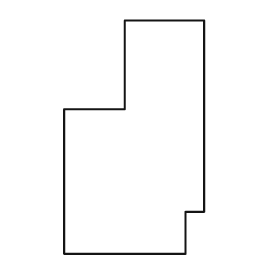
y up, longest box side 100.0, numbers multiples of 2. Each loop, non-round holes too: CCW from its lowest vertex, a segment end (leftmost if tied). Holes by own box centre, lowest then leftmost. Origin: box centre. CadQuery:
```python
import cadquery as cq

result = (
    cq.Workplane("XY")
    .moveTo(-30.0, -50.0)
    .lineTo(22.0, -50.0)
    .lineTo(22.0, -32.0)
    .lineTo(30.0, -32.0)
    .lineTo(30.0, 50.0)
    .lineTo(-4.0, 50.0)
    .lineTo(-4.0, 12.0)
    .lineTo(-30.0, 12.0)
    .close()
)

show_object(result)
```